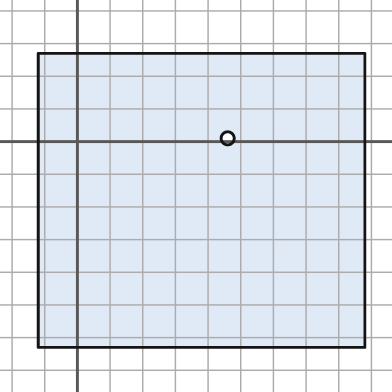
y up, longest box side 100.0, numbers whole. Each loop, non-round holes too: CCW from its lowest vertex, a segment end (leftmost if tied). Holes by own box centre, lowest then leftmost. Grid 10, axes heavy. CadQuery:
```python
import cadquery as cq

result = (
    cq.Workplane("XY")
    .moveTo(-12.0, -63.0)
    .lineTo(88.0, -63.0)
    .lineTo(88.0, 27.0)
    .lineTo(-12.0, 27.0)
    .close()
    .moveTo(46.0, 1.0)
    .circle(2.0)
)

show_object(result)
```